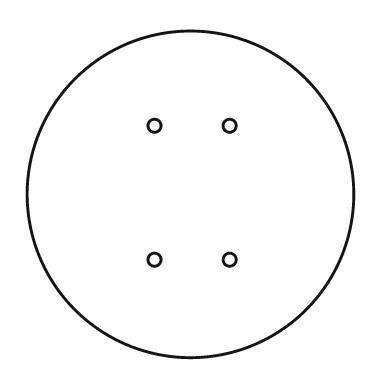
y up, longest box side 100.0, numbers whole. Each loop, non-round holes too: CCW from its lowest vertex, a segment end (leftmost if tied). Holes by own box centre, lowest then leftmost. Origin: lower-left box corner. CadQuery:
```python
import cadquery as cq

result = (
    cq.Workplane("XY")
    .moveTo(50.0, 50.0)
    .circle(50.0)
    .moveTo(39.0, 30.0)
    .circle(2.0)
    .moveTo(62.0, 30.0)
    .circle(2.0)
    .moveTo(39.0, 71.0)
    .circle(2.0)
    .moveTo(62.0, 71.0)
    .circle(2.0)
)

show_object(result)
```